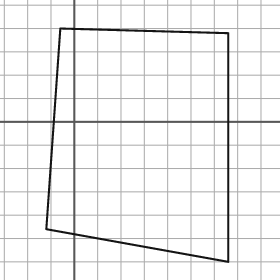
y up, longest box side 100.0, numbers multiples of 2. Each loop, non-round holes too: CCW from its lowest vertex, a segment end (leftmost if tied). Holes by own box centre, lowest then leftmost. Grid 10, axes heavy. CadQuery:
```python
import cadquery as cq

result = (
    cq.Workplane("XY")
    .moveTo(66.0, -60.0)
    .lineTo(66.0, 38.0)
    .lineTo(-6.0, 40.0)
    .lineTo(-12.0, -46.0)
    .close()
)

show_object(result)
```